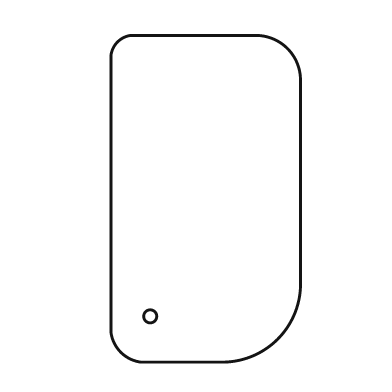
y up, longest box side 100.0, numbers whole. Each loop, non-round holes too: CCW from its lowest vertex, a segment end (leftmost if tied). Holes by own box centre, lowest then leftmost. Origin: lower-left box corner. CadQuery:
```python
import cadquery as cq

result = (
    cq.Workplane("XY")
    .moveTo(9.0, 0.0)
    .lineTo(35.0, 0.0)
    .threePointArc((51.0, 7.0), (58.0, 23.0))
    .lineTo(58.0, 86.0)
    .threePointArc((54.0, 96.0), (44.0, 100.0))
    .lineTo(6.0, 100.0)
    .threePointArc((2.0, 98.0), (0.0, 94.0))
    .lineTo(0.0, 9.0)
    .threePointArc((3.0, 3.0), (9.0, 0.0))
    .close()
    .moveTo(12.0, 14.0)
    .circle(2.0)
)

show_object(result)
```